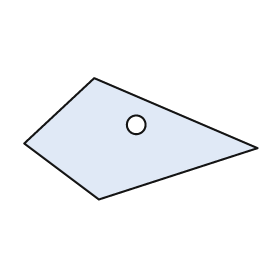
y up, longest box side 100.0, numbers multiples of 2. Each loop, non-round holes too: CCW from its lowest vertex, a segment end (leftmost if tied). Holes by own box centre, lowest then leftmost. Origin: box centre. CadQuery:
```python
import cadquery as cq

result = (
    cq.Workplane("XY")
    .moveTo(-18.0, -26.0)
    .lineTo(50.0, -4.0)
    .lineTo(-20.0, 26.0)
    .lineTo(-50.0, -2.0)
    .close()
    .moveTo(-2.0, 6.0)
    .circle(4.0)
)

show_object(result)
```